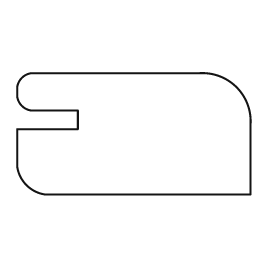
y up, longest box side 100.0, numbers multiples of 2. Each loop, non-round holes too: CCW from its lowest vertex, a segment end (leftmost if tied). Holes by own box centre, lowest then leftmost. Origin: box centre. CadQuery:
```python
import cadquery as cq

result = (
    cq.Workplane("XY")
    .moveTo(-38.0, -26.0)
    .lineTo(50.0, -26.0)
    .lineTo(50.0, 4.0)
    .threePointArc((44.0, 20.0), (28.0, 26.0))
    .lineTo(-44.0, 26.0)
    .threePointArc((-48.0, 24.0), (-50.0, 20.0))
    .lineTo(-50.0, 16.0)
    .threePointArc((-48.0, 12.0), (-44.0, 10.0))
    .lineTo(-24.0, 10.0)
    .lineTo(-24.0, 2.0)
    .lineTo(-50.0, 2.0)
    .lineTo(-50.0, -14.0)
    .threePointArc((-46.0, -22.0), (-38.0, -26.0))
    .close()
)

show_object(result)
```